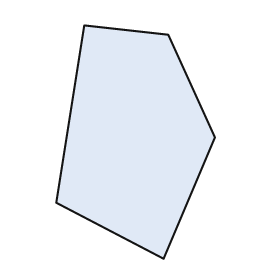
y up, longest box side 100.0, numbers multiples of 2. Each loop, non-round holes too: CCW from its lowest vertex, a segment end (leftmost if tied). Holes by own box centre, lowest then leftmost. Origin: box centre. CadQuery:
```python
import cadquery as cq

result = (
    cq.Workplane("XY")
    .moveTo(12.0, -50.0)
    .lineTo(34.0, 2.0)
    .lineTo(14.0, 46.0)
    .lineTo(-22.0, 50.0)
    .lineTo(-34.0, -26.0)
    .close()
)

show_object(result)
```